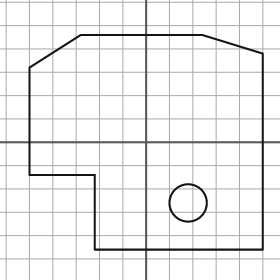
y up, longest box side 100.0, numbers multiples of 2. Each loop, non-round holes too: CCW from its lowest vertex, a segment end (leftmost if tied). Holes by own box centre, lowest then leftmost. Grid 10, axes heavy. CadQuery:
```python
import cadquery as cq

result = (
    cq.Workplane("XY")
    .moveTo(-22.0, -46.0)
    .lineTo(50.0, -46.0)
    .lineTo(50.0, 38.0)
    .lineTo(24.0, 46.0)
    .lineTo(-28.0, 46.0)
    .lineTo(-50.0, 32.0)
    .lineTo(-50.0, -14.0)
    .lineTo(-22.0, -14.0)
    .close()
    .moveTo(18.0, -26.0)
    .circle(8.0)
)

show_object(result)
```